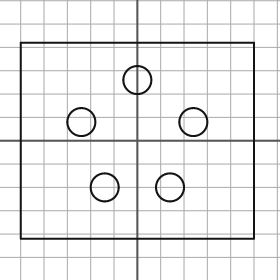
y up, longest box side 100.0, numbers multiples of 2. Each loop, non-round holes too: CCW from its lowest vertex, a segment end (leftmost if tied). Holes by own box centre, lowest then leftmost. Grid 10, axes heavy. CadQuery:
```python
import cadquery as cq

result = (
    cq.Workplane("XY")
    .moveTo(-50.0, -42.0)
    .lineTo(50.0, -42.0)
    .lineTo(50.0, 42.0)
    .lineTo(-50.0, 42.0)
    .close()
    .moveTo(-14.0, -20.0)
    .circle(6.0)
    .moveTo(14.0, -20.0)
    .circle(6.0)
    .moveTo(-24.0, 8.0)
    .circle(6.0)
    .moveTo(24.0, 8.0)
    .circle(6.0)
    .moveTo(0.0, 26.0)
    .circle(6.0)
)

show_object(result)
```